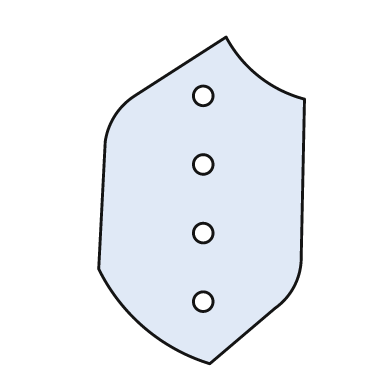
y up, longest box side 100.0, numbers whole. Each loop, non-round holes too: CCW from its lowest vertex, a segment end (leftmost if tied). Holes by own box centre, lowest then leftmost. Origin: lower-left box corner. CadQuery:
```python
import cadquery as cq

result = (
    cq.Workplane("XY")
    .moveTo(34.0, 0.0)
    .lineTo(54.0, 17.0)
    .threePointArc((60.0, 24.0), (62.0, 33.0))
    .lineTo(63.0, 81.0)
    .threePointArc((49.0, 88.0), (39.0, 100.0))
    .lineTo(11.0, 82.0)
    .threePointArc((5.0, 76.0), (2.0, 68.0))
    .lineTo(0.0, 29.0)
    .threePointArc((14.0, 11.0), (34.0, 0.0))
    .close()
    .moveTo(32.0, 19.0)
    .circle(3.0)
    .moveTo(32.0, 40.0)
    .circle(3.0)
    .moveTo(32.0, 61.0)
    .circle(3.0)
    .moveTo(32.0, 82.0)
    .circle(3.0)
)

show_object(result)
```